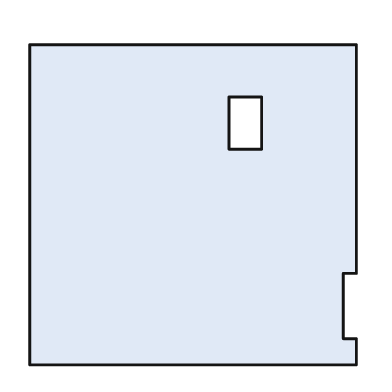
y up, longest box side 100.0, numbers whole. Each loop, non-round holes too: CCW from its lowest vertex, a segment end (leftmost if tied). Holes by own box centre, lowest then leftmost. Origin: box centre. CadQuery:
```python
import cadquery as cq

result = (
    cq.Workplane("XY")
    .moveTo(-50.0, -49.0)
    .lineTo(50.0, -49.0)
    .lineTo(50.0, -41.0)
    .lineTo(46.0, -41.0)
    .lineTo(46.0, -21.0)
    .lineTo(50.0, -21.0)
    .lineTo(50.0, 49.0)
    .lineTo(-50.0, 49.0)
    .close()
    .moveTo(11.0, 17.0)
    .lineTo(21.0, 17.0)
    .lineTo(21.0, 33.0)
    .lineTo(11.0, 33.0)
    .close()
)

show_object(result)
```